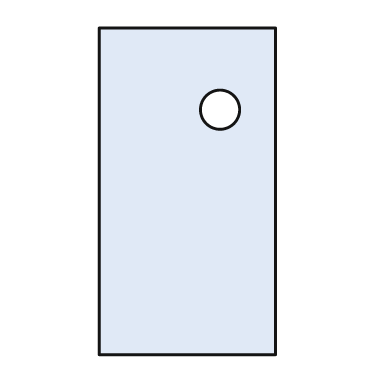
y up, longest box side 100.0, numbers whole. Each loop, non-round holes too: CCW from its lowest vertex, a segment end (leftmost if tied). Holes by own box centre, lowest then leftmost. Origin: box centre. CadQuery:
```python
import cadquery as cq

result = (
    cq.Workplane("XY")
    .moveTo(-27.0, -50.0)
    .lineTo(27.0, -50.0)
    .lineTo(27.0, 50.0)
    .lineTo(-27.0, 50.0)
    .close()
    .moveTo(10.0, 25.0)
    .circle(6.0)
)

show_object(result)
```